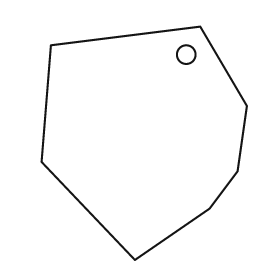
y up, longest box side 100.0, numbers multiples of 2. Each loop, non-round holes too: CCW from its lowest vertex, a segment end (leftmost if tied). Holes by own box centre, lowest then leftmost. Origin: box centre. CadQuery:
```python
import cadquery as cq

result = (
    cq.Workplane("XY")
    .moveTo(-4.0, -50.0)
    .lineTo(28.0, -28.0)
    .lineTo(40.0, -12.0)
    .lineTo(44.0, 16.0)
    .lineTo(24.0, 50.0)
    .lineTo(-40.0, 42.0)
    .lineTo(-44.0, -8.0)
    .close()
    .moveTo(18.0, 38.0)
    .circle(4.0)
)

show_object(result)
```